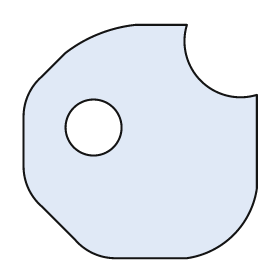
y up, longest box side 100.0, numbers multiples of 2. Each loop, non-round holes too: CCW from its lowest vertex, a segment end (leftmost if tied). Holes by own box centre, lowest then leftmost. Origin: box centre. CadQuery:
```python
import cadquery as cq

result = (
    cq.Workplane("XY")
    .moveTo(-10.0, -50.0)
    .lineTo(20.0, -50.0)
    .threePointArc((40.0, -40.0), (50.0, -20.0))
    .lineTo(50.0, 20.0)
    .threePointArc((26.0, 26.0), (20.0, 50.0))
    .lineTo(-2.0, 50.0)
    .threePointArc((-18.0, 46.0), (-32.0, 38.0))
    .lineTo(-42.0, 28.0)
    .threePointArc((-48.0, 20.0), (-50.0, 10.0))
    .lineTo(-50.0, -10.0)
    .threePointArc((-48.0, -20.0), (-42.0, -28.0))
    .lineTo(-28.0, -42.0)
    .threePointArc((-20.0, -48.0), (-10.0, -50.0))
    .close()
    .moveTo(-20.0, 6.0)
    .circle(12.0)
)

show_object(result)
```